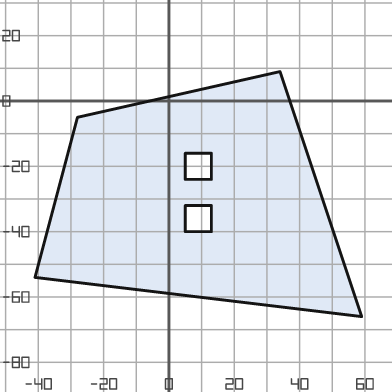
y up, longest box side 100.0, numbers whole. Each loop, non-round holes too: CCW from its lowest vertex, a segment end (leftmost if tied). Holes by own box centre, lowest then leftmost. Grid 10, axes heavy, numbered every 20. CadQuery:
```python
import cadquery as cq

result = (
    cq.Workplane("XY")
    .moveTo(59.0, -66.0)
    .lineTo(34.0, 9.0)
    .lineTo(-28.0, -5.0)
    .lineTo(-41.0, -54.0)
    .close()
    .moveTo(5.0, -40.0)
    .lineTo(13.0, -40.0)
    .lineTo(13.0, -32.0)
    .lineTo(5.0, -32.0)
    .close()
    .moveTo(5.0, -24.0)
    .lineTo(13.0, -24.0)
    .lineTo(13.0, -16.0)
    .lineTo(5.0, -16.0)
    .close()
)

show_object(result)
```